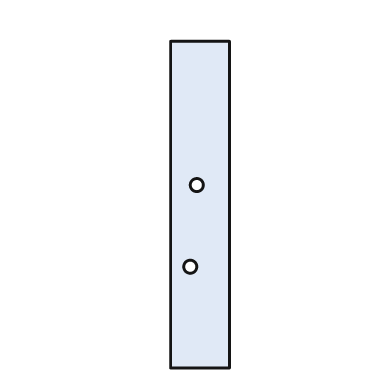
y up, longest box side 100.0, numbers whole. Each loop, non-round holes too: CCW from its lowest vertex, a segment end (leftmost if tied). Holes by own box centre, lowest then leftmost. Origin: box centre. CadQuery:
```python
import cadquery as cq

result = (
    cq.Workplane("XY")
    .moveTo(-9.0, -50.0)
    .lineTo(9.0, -50.0)
    .lineTo(9.0, 50.0)
    .lineTo(-9.0, 50.0)
    .close()
    .moveTo(-3.0, -19.0)
    .circle(2.0)
    .moveTo(-1.0, 6.0)
    .circle(2.0)
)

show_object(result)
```